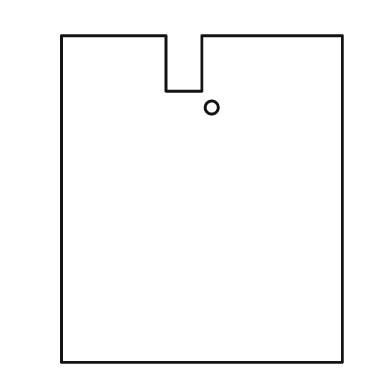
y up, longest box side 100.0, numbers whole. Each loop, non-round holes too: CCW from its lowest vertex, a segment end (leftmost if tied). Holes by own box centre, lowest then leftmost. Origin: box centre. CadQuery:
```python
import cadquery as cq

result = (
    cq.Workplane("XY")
    .moveTo(-43.0, -50.0)
    .lineTo(43.0, -50.0)
    .lineTo(43.0, 50.0)
    .lineTo(0.0, 50.0)
    .lineTo(0.0, 33.0)
    .lineTo(-11.0, 33.0)
    .lineTo(-11.0, 50.0)
    .lineTo(-43.0, 50.0)
    .close()
    .moveTo(3.0, 28.0)
    .circle(2.0)
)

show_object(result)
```